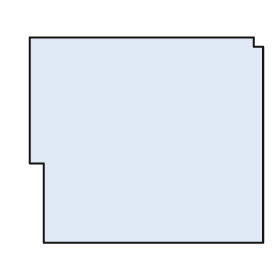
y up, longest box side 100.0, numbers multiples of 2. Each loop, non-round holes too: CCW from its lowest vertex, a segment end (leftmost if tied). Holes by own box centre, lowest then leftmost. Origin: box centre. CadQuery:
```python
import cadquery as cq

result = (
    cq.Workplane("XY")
    .moveTo(-44.0, -44.0)
    .lineTo(50.0, -44.0)
    .lineTo(50.0, 40.0)
    .lineTo(46.0, 40.0)
    .lineTo(46.0, 44.0)
    .lineTo(-50.0, 44.0)
    .lineTo(-50.0, -10.0)
    .lineTo(-44.0, -10.0)
    .close()
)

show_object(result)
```